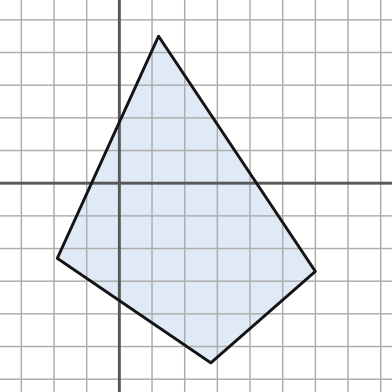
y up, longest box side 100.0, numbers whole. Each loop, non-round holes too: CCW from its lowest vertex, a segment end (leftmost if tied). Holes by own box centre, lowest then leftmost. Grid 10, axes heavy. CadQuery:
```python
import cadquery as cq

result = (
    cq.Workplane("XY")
    .moveTo(28.0, -55.0)
    .lineTo(60.0, -27.0)
    .lineTo(12.0, 45.0)
    .lineTo(-19.0, -23.0)
    .close()
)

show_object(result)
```